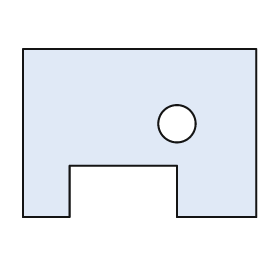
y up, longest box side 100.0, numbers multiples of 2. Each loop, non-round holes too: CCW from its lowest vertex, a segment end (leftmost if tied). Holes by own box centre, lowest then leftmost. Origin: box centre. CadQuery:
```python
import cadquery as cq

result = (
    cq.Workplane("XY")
    .moveTo(-50.0, -36.0)
    .lineTo(-30.0, -36.0)
    .lineTo(-30.0, -14.0)
    .lineTo(16.0, -14.0)
    .lineTo(16.0, -36.0)
    .lineTo(50.0, -36.0)
    .lineTo(50.0, 36.0)
    .lineTo(-50.0, 36.0)
    .close()
    .moveTo(16.0, 4.0)
    .circle(8.0)
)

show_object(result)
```